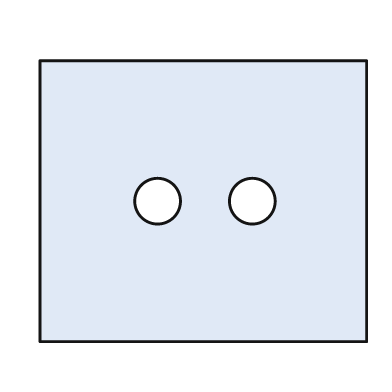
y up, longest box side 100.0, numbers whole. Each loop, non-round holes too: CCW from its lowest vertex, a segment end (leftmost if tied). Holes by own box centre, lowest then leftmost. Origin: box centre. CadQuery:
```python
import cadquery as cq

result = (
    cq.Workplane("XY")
    .moveTo(-50.0, -43.0)
    .lineTo(50.0, -43.0)
    .lineTo(50.0, 43.0)
    .lineTo(-50.0, 43.0)
    .close()
    .moveTo(-14.0, 0.0)
    .circle(7.0)
    .moveTo(15.0, 0.0)
    .circle(7.0)
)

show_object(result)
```